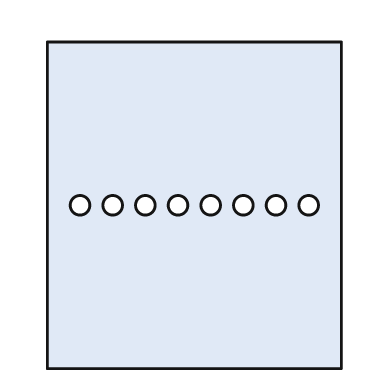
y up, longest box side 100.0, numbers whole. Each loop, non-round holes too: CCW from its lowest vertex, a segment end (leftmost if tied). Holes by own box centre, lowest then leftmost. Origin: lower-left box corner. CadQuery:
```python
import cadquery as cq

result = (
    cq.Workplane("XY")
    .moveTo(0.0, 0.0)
    .lineTo(90.0, 0.0)
    .lineTo(90.0, 100.0)
    .lineTo(0.0, 100.0)
    .close()
    .moveTo(10.0, 50.0)
    .circle(3.0)
    .moveTo(20.0, 50.0)
    .circle(3.0)
    .moveTo(30.0, 50.0)
    .circle(3.0)
    .moveTo(40.0, 50.0)
    .circle(3.0)
    .moveTo(50.0, 50.0)
    .circle(3.0)
    .moveTo(60.0, 50.0)
    .circle(3.0)
    .moveTo(70.0, 50.0)
    .circle(3.0)
    .moveTo(80.0, 50.0)
    .circle(3.0)
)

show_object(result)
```